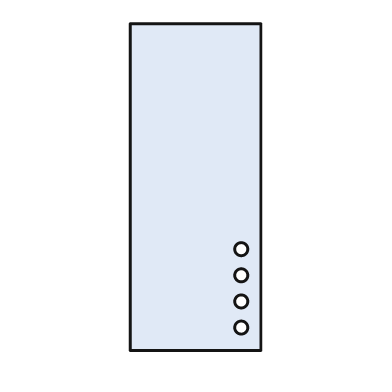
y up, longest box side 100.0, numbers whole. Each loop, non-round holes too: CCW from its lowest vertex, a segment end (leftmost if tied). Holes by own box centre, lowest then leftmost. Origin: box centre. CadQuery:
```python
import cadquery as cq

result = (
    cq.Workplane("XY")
    .moveTo(-20.0, -50.0)
    .lineTo(20.0, -50.0)
    .lineTo(20.0, 50.0)
    .lineTo(-20.0, 50.0)
    .close()
    .moveTo(14.0, -43.0)
    .circle(2.0)
    .moveTo(14.0, -35.0)
    .circle(2.0)
    .moveTo(14.0, -27.0)
    .circle(2.0)
    .moveTo(14.0, -19.0)
    .circle(2.0)
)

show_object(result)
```